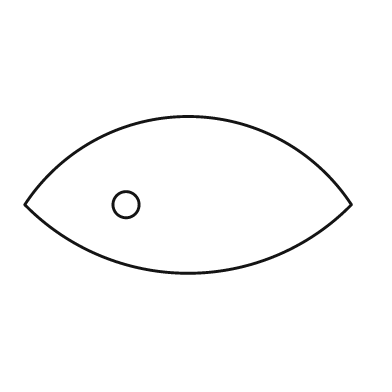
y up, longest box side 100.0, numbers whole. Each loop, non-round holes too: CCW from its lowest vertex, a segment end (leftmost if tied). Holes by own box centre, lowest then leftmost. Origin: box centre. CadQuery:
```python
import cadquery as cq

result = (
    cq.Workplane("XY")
    .moveTo(-50.0, -3.0)
    .threePointArc((0.0, -24.0), (50.0, -3.0))
    .threePointArc((0.0, 24.0), (-50.0, -3.0))
    .close()
    .moveTo(-19.0, -3.0)
    .circle(4.0)
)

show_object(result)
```